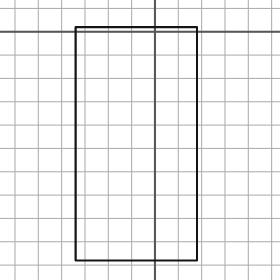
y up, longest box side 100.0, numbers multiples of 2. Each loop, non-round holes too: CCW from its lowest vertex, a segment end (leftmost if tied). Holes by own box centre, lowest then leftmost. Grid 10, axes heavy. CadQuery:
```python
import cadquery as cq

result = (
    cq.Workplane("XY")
    .moveTo(-34.0, -98.0)
    .lineTo(18.0, -98.0)
    .lineTo(18.0, 2.0)
    .lineTo(-34.0, 2.0)
    .close()
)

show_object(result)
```